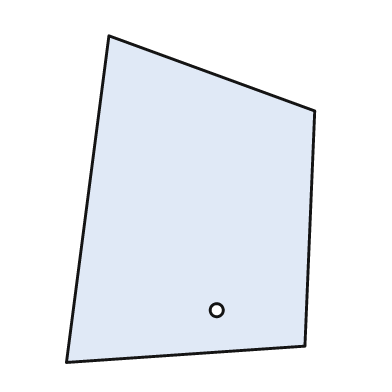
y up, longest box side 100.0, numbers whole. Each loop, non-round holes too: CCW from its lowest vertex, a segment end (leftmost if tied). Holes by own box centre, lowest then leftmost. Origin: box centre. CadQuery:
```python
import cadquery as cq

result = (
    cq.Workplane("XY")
    .moveTo(-38.0, -50.0)
    .lineTo(35.0, -45.0)
    .lineTo(38.0, 27.0)
    .lineTo(-25.0, 50.0)
    .close()
    .moveTo(8.0, -34.0)
    .circle(2.0)
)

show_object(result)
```